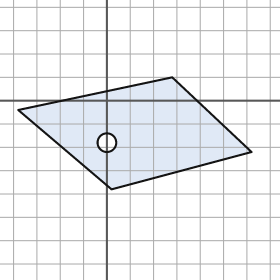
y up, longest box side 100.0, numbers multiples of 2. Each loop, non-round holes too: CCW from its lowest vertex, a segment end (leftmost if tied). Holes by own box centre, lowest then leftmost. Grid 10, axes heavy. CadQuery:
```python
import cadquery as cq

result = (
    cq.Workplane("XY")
    .moveTo(2.0, -38.0)
    .lineTo(62.0, -22.0)
    .lineTo(28.0, 10.0)
    .lineTo(-38.0, -4.0)
    .close()
    .moveTo(0.0, -18.0)
    .circle(4.0)
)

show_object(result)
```